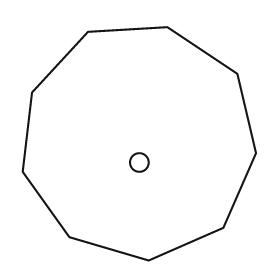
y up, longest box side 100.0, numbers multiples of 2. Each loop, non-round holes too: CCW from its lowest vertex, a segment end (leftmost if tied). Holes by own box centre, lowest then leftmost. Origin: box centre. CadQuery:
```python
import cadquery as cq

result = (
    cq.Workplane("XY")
    .moveTo(4.0, -50.0)
    .lineTo(36.0, -36.0)
    .lineTo(50.0, -4.0)
    .lineTo(42.0, 30.0)
    .lineTo(12.0, 50.0)
    .lineTo(-22.0, 48.0)
    .lineTo(-46.0, 22.0)
    .lineTo(-50.0, -12.0)
    .lineTo(-30.0, -40.0)
    .close()
    .moveTo(0.0, -8.0)
    .circle(4.0)
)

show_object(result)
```